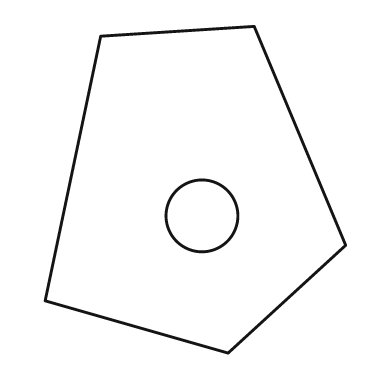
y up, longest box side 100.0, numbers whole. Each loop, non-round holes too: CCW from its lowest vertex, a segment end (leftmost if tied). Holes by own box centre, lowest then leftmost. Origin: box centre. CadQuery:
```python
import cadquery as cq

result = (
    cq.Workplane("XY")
    .moveTo(10.0, -50.0)
    .lineTo(46.0, -17.0)
    .lineTo(18.0, 50.0)
    .lineTo(-29.0, 47.0)
    .lineTo(-46.0, -34.0)
    .close()
    .moveTo(2.0, -8.0)
    .circle(11.0)
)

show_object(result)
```